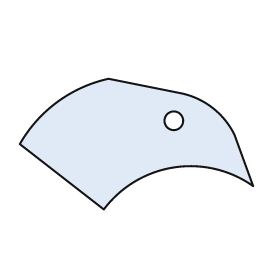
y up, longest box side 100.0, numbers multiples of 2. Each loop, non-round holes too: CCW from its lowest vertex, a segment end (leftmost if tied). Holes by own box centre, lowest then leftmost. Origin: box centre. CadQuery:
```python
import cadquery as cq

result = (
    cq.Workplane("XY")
    .moveTo(-14.0, -28.0)
    .threePointArc((16.0, -10.0), (50.0, -18.0))
    .lineTo(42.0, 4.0)
    .threePointArc((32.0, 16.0), (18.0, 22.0))
    .lineTo(-12.0, 28.0)
    .threePointArc((-34.0, 18.0), (-50.0, 0.0))
    .close()
    .moveTo(16.0, 10.0)
    .circle(4.0)
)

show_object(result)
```